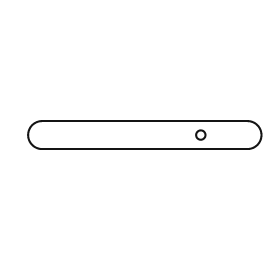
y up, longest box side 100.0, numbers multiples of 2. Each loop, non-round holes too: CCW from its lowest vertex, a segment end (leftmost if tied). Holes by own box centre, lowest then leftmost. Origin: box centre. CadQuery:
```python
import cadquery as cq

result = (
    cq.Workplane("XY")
    .moveTo(-44.0, -6.0)
    .lineTo(44.0, -6.0)
    .threePointArc((50.0, 0.0), (44.0, 6.0))
    .lineTo(-44.0, 6.0)
    .threePointArc((-50.0, 0.0), (-44.0, -6.0))
    .close()
    .moveTo(24.0, 0.0)
    .circle(2.0)
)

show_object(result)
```